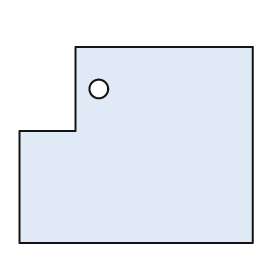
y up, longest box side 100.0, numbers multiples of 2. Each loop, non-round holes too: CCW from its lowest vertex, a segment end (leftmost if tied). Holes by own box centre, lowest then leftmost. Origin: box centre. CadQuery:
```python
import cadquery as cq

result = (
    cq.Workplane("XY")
    .moveTo(-50.0, -42.0)
    .lineTo(50.0, -42.0)
    .lineTo(50.0, 42.0)
    .lineTo(-26.0, 42.0)
    .lineTo(-26.0, 6.0)
    .lineTo(-50.0, 6.0)
    .close()
    .moveTo(-16.0, 24.0)
    .circle(4.0)
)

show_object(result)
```